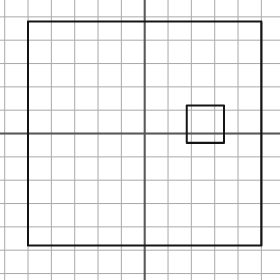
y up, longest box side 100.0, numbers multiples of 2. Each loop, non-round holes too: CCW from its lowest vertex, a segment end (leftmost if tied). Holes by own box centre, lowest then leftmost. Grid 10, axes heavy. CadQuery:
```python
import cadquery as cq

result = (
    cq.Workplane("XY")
    .moveTo(-50.0, -48.0)
    .lineTo(50.0, -48.0)
    .lineTo(50.0, 48.0)
    .lineTo(-50.0, 48.0)
    .close()
    .moveTo(18.0, -4.0)
    .lineTo(34.0, -4.0)
    .lineTo(34.0, 12.0)
    .lineTo(18.0, 12.0)
    .close()
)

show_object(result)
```